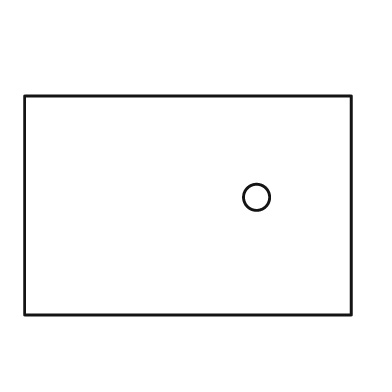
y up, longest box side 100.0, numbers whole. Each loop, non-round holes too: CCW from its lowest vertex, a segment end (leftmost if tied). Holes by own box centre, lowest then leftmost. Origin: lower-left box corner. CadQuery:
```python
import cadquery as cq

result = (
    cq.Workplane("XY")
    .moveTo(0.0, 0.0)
    .lineTo(100.0, 0.0)
    .lineTo(100.0, 67.0)
    .lineTo(0.0, 67.0)
    .close()
    .moveTo(71.0, 36.0)
    .circle(4.0)
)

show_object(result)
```